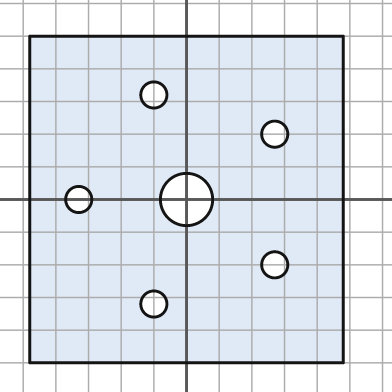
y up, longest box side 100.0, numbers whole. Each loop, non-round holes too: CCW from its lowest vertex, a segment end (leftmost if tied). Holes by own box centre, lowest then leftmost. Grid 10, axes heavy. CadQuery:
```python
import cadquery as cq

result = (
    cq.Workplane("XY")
    .moveTo(-48.0, -50.0)
    .lineTo(48.0, -50.0)
    .lineTo(48.0, 50.0)
    .lineTo(-48.0, 50.0)
    .close()
    .moveTo(-10.0, -32.0)
    .circle(4.0)
    .moveTo(27.0, -20.0)
    .circle(4.0)
    .moveTo(-33.0, 0.0)
    .circle(4.0)
    .moveTo(0.0, 0.0)
    .circle(8.0)
    .moveTo(27.0, 20.0)
    .circle(4.0)
    .moveTo(-10.0, 32.0)
    .circle(4.0)
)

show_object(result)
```